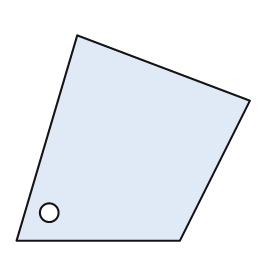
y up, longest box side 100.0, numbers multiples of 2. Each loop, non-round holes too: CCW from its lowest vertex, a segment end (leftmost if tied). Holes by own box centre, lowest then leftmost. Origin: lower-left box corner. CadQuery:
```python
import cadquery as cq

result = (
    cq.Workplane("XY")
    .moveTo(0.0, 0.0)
    .lineTo(70.0, 0.0)
    .lineTo(100.0, 60.0)
    .lineTo(26.0, 88.0)
    .close()
    .moveTo(14.0, 12.0)
    .circle(4.0)
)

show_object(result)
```